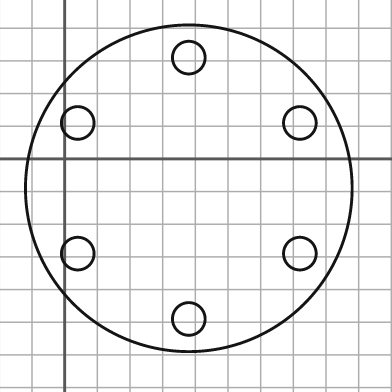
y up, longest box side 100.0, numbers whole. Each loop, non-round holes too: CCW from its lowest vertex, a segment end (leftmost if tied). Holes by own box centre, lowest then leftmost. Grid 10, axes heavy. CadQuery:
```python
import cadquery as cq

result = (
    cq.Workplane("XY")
    .moveTo(38.0, -9.0)
    .circle(50.0)
    .moveTo(38.0, -49.0)
    .circle(5.0)
    .moveTo(4.0, -29.0)
    .circle(5.0)
    .moveTo(72.0, -29.0)
    .circle(5.0)
    .moveTo(4.0, 11.0)
    .circle(5.0)
    .moveTo(72.0, 11.0)
    .circle(5.0)
    .moveTo(38.0, 31.0)
    .circle(5.0)
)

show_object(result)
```